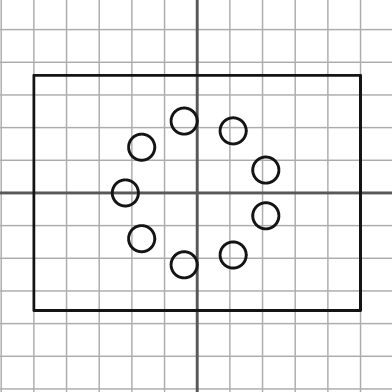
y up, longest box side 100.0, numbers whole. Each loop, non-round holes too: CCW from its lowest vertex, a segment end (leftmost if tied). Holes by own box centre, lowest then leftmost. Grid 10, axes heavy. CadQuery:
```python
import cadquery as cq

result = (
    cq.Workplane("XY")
    .moveTo(-50.0, -36.0)
    .lineTo(50.0, -36.0)
    .lineTo(50.0, 36.0)
    .lineTo(-50.0, 36.0)
    .close()
    .moveTo(-4.0, -22.0)
    .circle(4.0)
    .moveTo(11.0, -19.0)
    .circle(4.0)
    .moveTo(-17.0, -14.0)
    .circle(4.0)
    .moveTo(21.0, -7.0)
    .circle(4.0)
    .moveTo(-22.0, 0.0)
    .circle(4.0)
    .moveTo(21.0, 7.0)
    .circle(4.0)
    .moveTo(-17.0, 14.0)
    .circle(4.0)
    .moveTo(11.0, 19.0)
    .circle(4.0)
    .moveTo(-4.0, 22.0)
    .circle(4.0)
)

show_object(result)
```